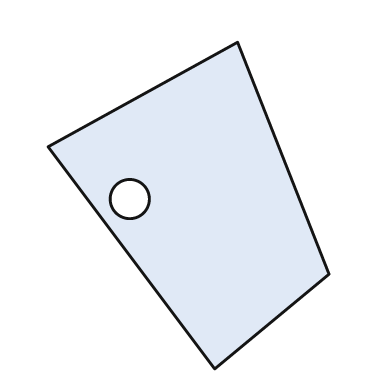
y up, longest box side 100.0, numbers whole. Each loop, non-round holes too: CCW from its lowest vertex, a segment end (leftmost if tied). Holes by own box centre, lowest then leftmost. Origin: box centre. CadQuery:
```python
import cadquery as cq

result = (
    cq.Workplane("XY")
    .moveTo(8.0, -50.0)
    .lineTo(43.0, -21.0)
    .lineTo(15.0, 50.0)
    .lineTo(-43.0, 18.0)
    .close()
    .moveTo(-18.0, 2.0)
    .circle(6.0)
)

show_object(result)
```